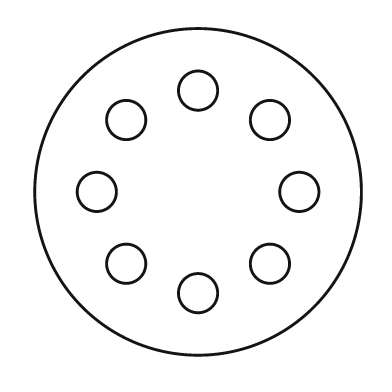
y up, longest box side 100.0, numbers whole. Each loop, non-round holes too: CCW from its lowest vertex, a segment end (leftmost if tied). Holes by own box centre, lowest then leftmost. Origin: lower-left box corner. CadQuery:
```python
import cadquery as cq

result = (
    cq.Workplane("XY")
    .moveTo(50.0, 50.0)
    .circle(50.0)
    .moveTo(50.0, 19.0)
    .circle(6.0)
    .moveTo(28.0, 28.0)
    .circle(6.0)
    .moveTo(72.0, 28.0)
    .circle(6.0)
    .moveTo(19.0, 50.0)
    .circle(6.0)
    .moveTo(81.0, 50.0)
    .circle(6.0)
    .moveTo(28.0, 72.0)
    .circle(6.0)
    .moveTo(72.0, 72.0)
    .circle(6.0)
    .moveTo(50.0, 81.0)
    .circle(6.0)
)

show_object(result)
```